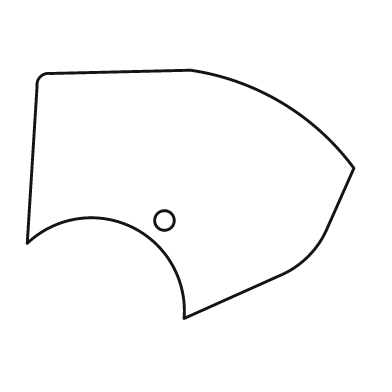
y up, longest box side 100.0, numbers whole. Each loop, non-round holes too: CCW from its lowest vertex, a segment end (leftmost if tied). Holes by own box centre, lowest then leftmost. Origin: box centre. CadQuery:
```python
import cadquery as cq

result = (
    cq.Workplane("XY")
    .moveTo(-2.0, -38.0)
    .lineTo(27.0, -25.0)
    .threePointArc((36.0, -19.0), (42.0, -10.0))
    .lineTo(50.0, 8.0)
    .threePointArc((28.0, 28.0), (0.0, 38.0))
    .lineTo(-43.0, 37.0)
    .threePointArc((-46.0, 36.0), (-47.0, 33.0))
    .lineTo(-50.0, -15.0)
    .threePointArc((-18.0, -10.0), (-2.0, -38.0))
    .close()
    .moveTo(-8.0, -8.0)
    .circle(3.0)
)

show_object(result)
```